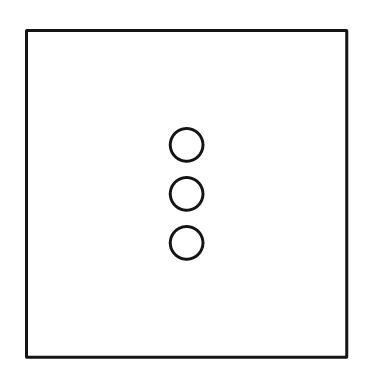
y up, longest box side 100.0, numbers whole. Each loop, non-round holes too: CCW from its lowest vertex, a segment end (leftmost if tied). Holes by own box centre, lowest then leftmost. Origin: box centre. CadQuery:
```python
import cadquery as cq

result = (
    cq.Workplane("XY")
    .moveTo(-49.0, -50.0)
    .lineTo(49.0, -50.0)
    .lineTo(49.0, 50.0)
    .lineTo(-49.0, 50.0)
    .close()
    .moveTo(0.0, -15.0)
    .circle(5.0)
    .moveTo(0.0, 0.0)
    .circle(5.0)
    .moveTo(0.0, 15.0)
    .circle(5.0)
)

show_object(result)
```